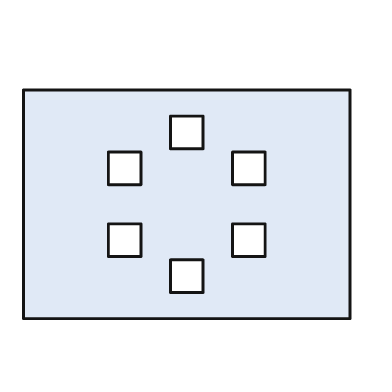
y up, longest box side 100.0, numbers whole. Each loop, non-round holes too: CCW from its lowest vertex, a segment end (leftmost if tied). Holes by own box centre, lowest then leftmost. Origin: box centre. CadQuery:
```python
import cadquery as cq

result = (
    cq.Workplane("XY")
    .moveTo(-50.0, -35.0)
    .lineTo(50.0, -35.0)
    .lineTo(50.0, 35.0)
    .lineTo(-50.0, 35.0)
    .close()
    .moveTo(-5.0, -27.0)
    .lineTo(5.0, -27.0)
    .lineTo(5.0, -17.0)
    .lineTo(-5.0, -17.0)
    .close()
    .moveTo(-24.0, -16.0)
    .lineTo(-14.0, -16.0)
    .lineTo(-14.0, -6.0)
    .lineTo(-24.0, -6.0)
    .close()
    .moveTo(14.0, -16.0)
    .lineTo(24.0, -16.0)
    .lineTo(24.0, -6.0)
    .lineTo(14.0, -6.0)
    .close()
    .moveTo(-24.0, 6.0)
    .lineTo(-14.0, 6.0)
    .lineTo(-14.0, 16.0)
    .lineTo(-24.0, 16.0)
    .close()
    .moveTo(14.0, 6.0)
    .lineTo(24.0, 6.0)
    .lineTo(24.0, 16.0)
    .lineTo(14.0, 16.0)
    .close()
    .moveTo(-5.0, 17.0)
    .lineTo(5.0, 17.0)
    .lineTo(5.0, 27.0)
    .lineTo(-5.0, 27.0)
    .close()
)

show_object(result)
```